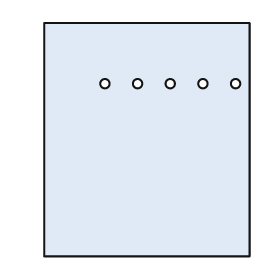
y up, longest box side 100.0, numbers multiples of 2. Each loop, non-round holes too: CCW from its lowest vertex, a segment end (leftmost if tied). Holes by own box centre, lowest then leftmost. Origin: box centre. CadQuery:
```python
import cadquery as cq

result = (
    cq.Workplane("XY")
    .moveTo(-44.0, -50.0)
    .lineTo(44.0, -50.0)
    .lineTo(44.0, 50.0)
    .lineTo(-44.0, 50.0)
    .close()
    .moveTo(-18.0, 24.0)
    .circle(2.0)
    .moveTo(-4.0, 24.0)
    .circle(2.0)
    .moveTo(10.0, 24.0)
    .circle(2.0)
    .moveTo(24.0, 24.0)
    .circle(2.0)
    .moveTo(38.0, 24.0)
    .circle(2.0)
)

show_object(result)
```